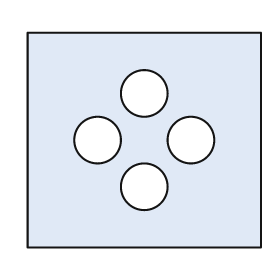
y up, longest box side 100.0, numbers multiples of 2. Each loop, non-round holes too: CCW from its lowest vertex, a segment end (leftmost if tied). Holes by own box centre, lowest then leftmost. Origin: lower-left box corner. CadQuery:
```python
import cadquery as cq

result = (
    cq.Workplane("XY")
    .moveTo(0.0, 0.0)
    .lineTo(100.0, 0.0)
    .lineTo(100.0, 92.0)
    .lineTo(0.0, 92.0)
    .close()
    .moveTo(50.0, 26.0)
    .circle(10.0)
    .moveTo(30.0, 46.0)
    .circle(10.0)
    .moveTo(70.0, 46.0)
    .circle(10.0)
    .moveTo(50.0, 66.0)
    .circle(10.0)
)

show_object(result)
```